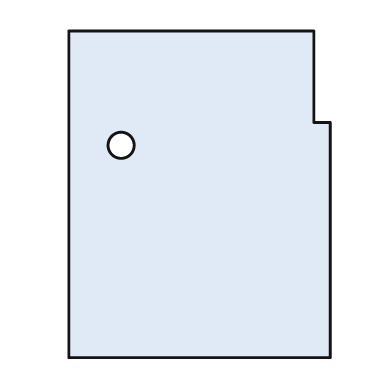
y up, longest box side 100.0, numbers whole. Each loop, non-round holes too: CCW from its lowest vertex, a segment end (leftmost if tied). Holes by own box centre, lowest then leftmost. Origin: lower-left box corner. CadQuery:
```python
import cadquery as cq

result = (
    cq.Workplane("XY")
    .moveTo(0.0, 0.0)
    .lineTo(80.0, 0.0)
    .lineTo(80.0, 72.0)
    .lineTo(75.0, 72.0)
    .lineTo(75.0, 100.0)
    .lineTo(0.0, 100.0)
    .close()
    .moveTo(16.0, 65.0)
    .circle(4.0)
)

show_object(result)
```